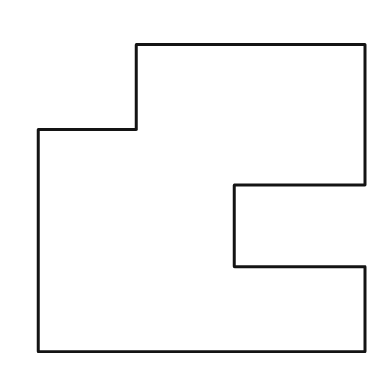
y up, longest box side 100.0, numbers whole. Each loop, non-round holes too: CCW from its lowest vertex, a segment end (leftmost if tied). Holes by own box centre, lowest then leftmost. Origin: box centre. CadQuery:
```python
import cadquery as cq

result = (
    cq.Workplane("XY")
    .moveTo(-50.0, -47.0)
    .lineTo(50.0, -47.0)
    .lineTo(50.0, -21.0)
    .lineTo(10.0, -21.0)
    .lineTo(10.0, 4.0)
    .lineTo(50.0, 4.0)
    .lineTo(50.0, 47.0)
    .lineTo(-20.0, 47.0)
    .lineTo(-20.0, 21.0)
    .lineTo(-50.0, 21.0)
    .close()
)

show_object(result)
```